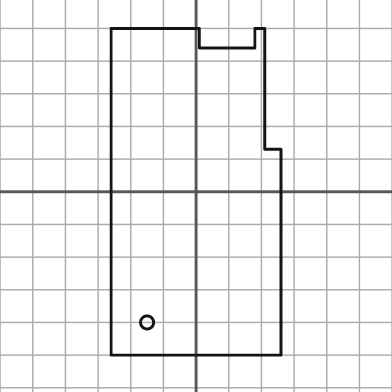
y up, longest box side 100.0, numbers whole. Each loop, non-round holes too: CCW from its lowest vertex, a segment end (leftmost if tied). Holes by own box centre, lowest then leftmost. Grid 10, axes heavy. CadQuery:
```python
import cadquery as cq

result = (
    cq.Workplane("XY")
    .moveTo(-26.0, -50.0)
    .lineTo(26.0, -50.0)
    .lineTo(26.0, 13.0)
    .lineTo(21.0, 13.0)
    .lineTo(21.0, 50.0)
    .lineTo(18.0, 50.0)
    .lineTo(18.0, 44.0)
    .lineTo(1.0, 44.0)
    .lineTo(1.0, 50.0)
    .lineTo(-26.0, 50.0)
    .close()
    .moveTo(-15.0, -40.0)
    .circle(2.0)
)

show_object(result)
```